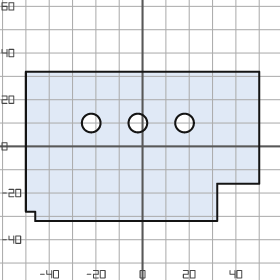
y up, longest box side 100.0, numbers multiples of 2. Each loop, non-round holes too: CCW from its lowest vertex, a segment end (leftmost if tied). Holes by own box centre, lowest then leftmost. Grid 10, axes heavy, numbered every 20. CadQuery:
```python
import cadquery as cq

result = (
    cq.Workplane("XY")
    .moveTo(-46.0, -32.0)
    .lineTo(32.0, -32.0)
    .lineTo(32.0, -16.0)
    .lineTo(50.0, -16.0)
    .lineTo(50.0, 32.0)
    .lineTo(-50.0, 32.0)
    .lineTo(-50.0, -28.0)
    .lineTo(-46.0, -28.0)
    .close()
    .moveTo(-22.0, 10.0)
    .circle(4.0)
    .moveTo(-2.0, 10.0)
    .circle(4.0)
    .moveTo(18.0, 10.0)
    .circle(4.0)
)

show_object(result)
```